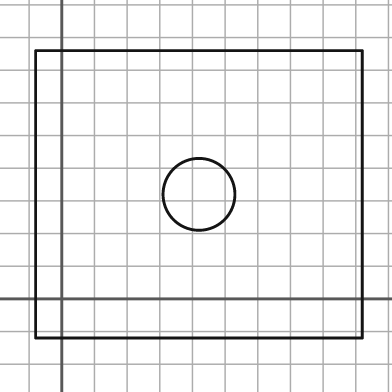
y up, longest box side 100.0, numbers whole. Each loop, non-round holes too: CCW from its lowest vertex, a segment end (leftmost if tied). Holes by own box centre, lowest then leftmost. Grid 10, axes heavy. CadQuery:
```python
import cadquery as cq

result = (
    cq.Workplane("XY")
    .moveTo(-8.0, -12.0)
    .lineTo(92.0, -12.0)
    .lineTo(92.0, 76.0)
    .lineTo(-8.0, 76.0)
    .close()
    .moveTo(42.0, 32.0)
    .circle(11.0)
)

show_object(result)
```